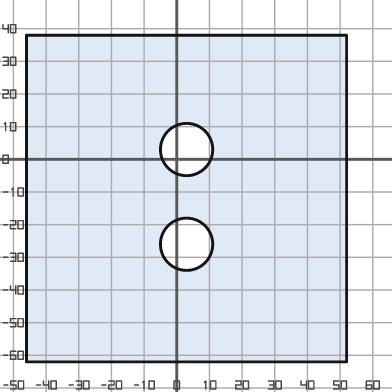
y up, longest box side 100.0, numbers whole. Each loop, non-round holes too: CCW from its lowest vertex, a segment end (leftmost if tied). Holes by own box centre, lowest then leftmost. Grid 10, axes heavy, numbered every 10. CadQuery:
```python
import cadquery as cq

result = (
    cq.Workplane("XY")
    .moveTo(-46.0, -62.0)
    .lineTo(52.0, -62.0)
    .lineTo(52.0, 38.0)
    .lineTo(-46.0, 38.0)
    .close()
    .moveTo(3.0, -26.0)
    .circle(8.0)
    .moveTo(3.0, 3.0)
    .circle(8.0)
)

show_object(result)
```